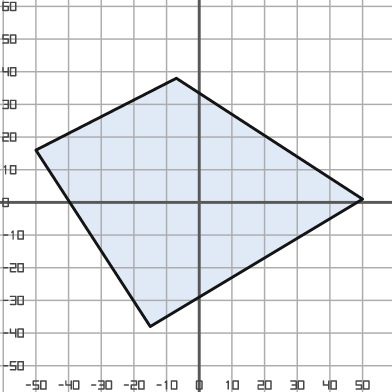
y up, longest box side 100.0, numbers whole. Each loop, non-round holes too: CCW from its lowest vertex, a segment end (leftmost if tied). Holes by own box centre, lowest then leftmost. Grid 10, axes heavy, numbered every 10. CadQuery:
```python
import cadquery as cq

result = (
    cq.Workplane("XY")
    .moveTo(-15.0, -38.0)
    .lineTo(50.0, 1.0)
    .lineTo(-7.0, 38.0)
    .lineTo(-50.0, 16.0)
    .close()
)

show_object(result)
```